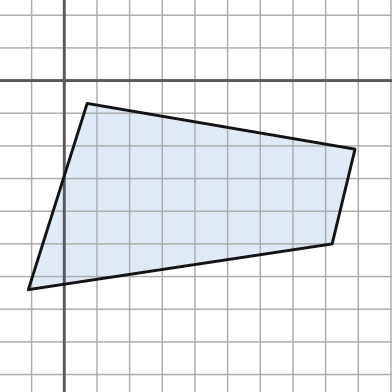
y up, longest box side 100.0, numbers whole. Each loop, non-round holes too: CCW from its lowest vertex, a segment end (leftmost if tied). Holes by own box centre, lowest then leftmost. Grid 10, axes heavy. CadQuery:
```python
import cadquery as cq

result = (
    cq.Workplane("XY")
    .moveTo(-11.0, -64.0)
    .lineTo(82.0, -50.0)
    .lineTo(89.0, -21.0)
    .lineTo(7.0, -7.0)
    .close()
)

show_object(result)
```